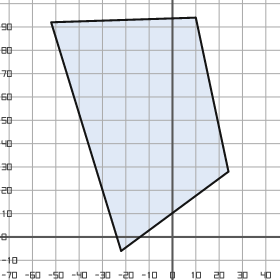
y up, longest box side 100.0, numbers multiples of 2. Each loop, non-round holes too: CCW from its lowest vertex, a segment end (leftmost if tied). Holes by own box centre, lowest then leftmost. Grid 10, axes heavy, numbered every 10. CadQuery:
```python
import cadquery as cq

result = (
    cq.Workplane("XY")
    .moveTo(-22.0, -6.0)
    .lineTo(24.0, 28.0)
    .lineTo(10.0, 94.0)
    .lineTo(-52.0, 92.0)
    .close()
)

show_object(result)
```